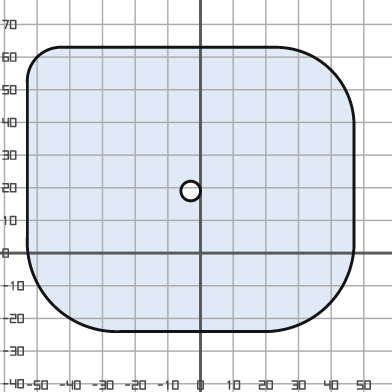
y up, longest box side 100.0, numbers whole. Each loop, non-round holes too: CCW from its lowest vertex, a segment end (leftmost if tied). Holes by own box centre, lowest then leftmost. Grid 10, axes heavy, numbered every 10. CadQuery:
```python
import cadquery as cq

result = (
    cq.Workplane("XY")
    .moveTo(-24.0, -24.0)
    .lineTo(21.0, -24.0)
    .threePointArc((39.0, -16.0), (47.0, 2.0))
    .lineTo(47.0, 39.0)
    .threePointArc((40.0, 56.0), (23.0, 63.0))
    .lineTo(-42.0, 63.0)
    .threePointArc((-50.0, 60.0), (-53.0, 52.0))
    .lineTo(-53.0, 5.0)
    .threePointArc((-45.0, -16.0), (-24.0, -24.0))
    .close()
    .moveTo(-3.0, 19.0)
    .circle(3.0)
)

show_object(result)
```